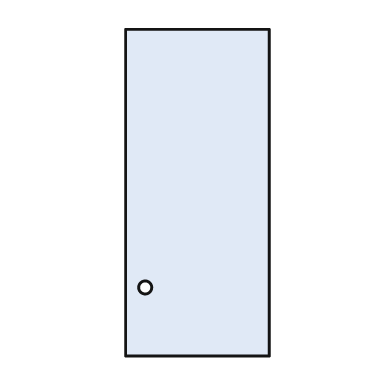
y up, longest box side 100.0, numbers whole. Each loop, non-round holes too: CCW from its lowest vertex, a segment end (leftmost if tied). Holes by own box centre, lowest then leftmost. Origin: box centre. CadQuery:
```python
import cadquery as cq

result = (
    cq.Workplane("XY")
    .moveTo(-22.0, -50.0)
    .lineTo(22.0, -50.0)
    .lineTo(22.0, 50.0)
    .lineTo(-22.0, 50.0)
    .close()
    .moveTo(-16.0, -29.0)
    .circle(2.0)
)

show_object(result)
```